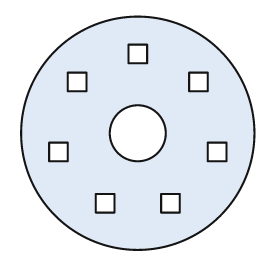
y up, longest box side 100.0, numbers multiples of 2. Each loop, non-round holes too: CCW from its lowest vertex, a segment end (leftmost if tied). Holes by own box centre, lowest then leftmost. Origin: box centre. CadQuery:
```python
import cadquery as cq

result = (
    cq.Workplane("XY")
    .moveTo(0.0, 0.0)
    .circle(50.0)
    .moveTo(-18.0, -34.0)
    .lineTo(-10.0, -34.0)
    .lineTo(-10.0, -26.0)
    .lineTo(-18.0, -26.0)
    .close()
    .moveTo(10.0, -34.0)
    .lineTo(18.0, -34.0)
    .lineTo(18.0, -26.0)
    .lineTo(10.0, -26.0)
    .close()
    .moveTo(-38.0, -12.0)
    .lineTo(-30.0, -12.0)
    .lineTo(-30.0, -4.0)
    .lineTo(-38.0, -4.0)
    .close()
    .moveTo(30.0, -12.0)
    .lineTo(38.0, -12.0)
    .lineTo(38.0, -4.0)
    .lineTo(30.0, -4.0)
    .close()
    .moveTo(0.0, 0.0)
    .circle(12.0)
    .moveTo(-30.0, 18.0)
    .lineTo(-22.0, 18.0)
    .lineTo(-22.0, 26.0)
    .lineTo(-30.0, 26.0)
    .close()
    .moveTo(22.0, 18.0)
    .lineTo(30.0, 18.0)
    .lineTo(30.0, 26.0)
    .lineTo(22.0, 26.0)
    .close()
    .moveTo(-4.0, 30.0)
    .lineTo(4.0, 30.0)
    .lineTo(4.0, 38.0)
    .lineTo(-4.0, 38.0)
    .close()
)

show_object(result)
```